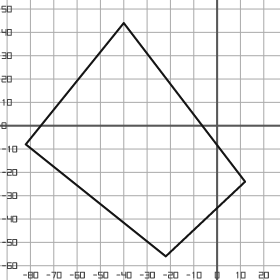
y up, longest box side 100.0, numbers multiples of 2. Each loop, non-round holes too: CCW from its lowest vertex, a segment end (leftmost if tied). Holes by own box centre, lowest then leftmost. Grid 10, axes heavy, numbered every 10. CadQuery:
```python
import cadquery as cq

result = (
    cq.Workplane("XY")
    .moveTo(-22.0, -56.0)
    .lineTo(12.0, -24.0)
    .lineTo(-40.0, 44.0)
    .lineTo(-82.0, -8.0)
    .close()
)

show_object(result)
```